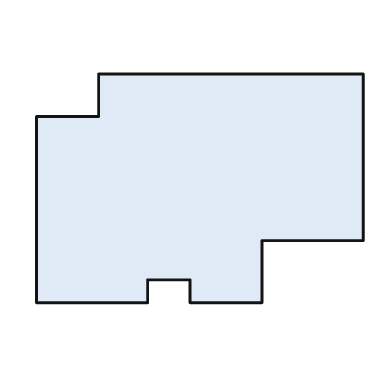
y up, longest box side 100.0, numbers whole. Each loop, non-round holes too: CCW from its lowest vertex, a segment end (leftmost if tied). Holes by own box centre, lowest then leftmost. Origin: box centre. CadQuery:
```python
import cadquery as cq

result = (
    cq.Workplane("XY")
    .moveTo(-50.0, -35.0)
    .lineTo(-16.0, -35.0)
    .lineTo(-16.0, -28.0)
    .lineTo(-3.0, -28.0)
    .lineTo(-3.0, -35.0)
    .lineTo(19.0, -35.0)
    .lineTo(19.0, -16.0)
    .lineTo(50.0, -16.0)
    .lineTo(50.0, 35.0)
    .lineTo(-31.0, 35.0)
    .lineTo(-31.0, 22.0)
    .lineTo(-50.0, 22.0)
    .close()
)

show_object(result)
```